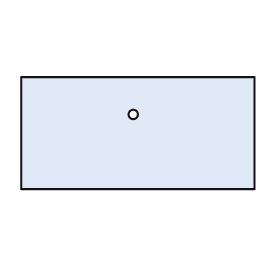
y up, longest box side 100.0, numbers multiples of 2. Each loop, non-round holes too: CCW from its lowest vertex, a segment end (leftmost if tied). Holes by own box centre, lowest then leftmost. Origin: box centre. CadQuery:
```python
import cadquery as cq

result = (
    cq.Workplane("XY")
    .moveTo(-50.0, -24.0)
    .lineTo(50.0, -24.0)
    .lineTo(50.0, 24.0)
    .lineTo(-50.0, 24.0)
    .close()
    .moveTo(-2.0, 8.0)
    .circle(2.0)
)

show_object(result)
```